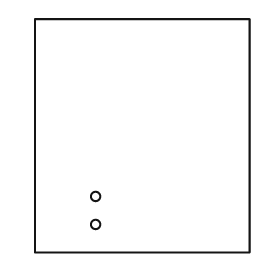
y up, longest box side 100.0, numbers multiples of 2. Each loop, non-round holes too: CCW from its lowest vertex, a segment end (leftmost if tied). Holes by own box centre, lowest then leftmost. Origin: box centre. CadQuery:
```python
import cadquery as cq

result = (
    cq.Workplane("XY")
    .moveTo(-46.0, -50.0)
    .lineTo(46.0, -50.0)
    .lineTo(46.0, 50.0)
    .lineTo(-46.0, 50.0)
    .close()
    .moveTo(-20.0, -38.0)
    .circle(2.0)
    .moveTo(-20.0, -26.0)
    .circle(2.0)
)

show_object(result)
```